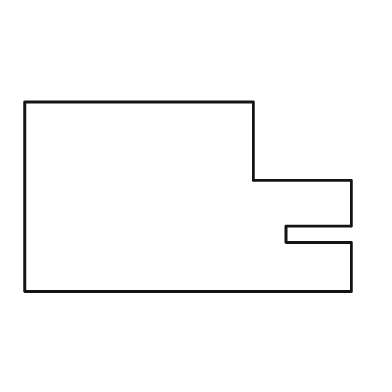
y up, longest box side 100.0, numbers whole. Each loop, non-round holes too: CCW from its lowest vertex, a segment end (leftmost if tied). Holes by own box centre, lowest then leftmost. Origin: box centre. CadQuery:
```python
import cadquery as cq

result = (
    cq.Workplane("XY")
    .moveTo(-50.0, -29.0)
    .lineTo(50.0, -29.0)
    .lineTo(50.0, -14.0)
    .lineTo(30.0, -14.0)
    .lineTo(30.0, -9.0)
    .lineTo(50.0, -9.0)
    .lineTo(50.0, 5.0)
    .lineTo(20.0, 5.0)
    .lineTo(20.0, 29.0)
    .lineTo(-50.0, 29.0)
    .close()
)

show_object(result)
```